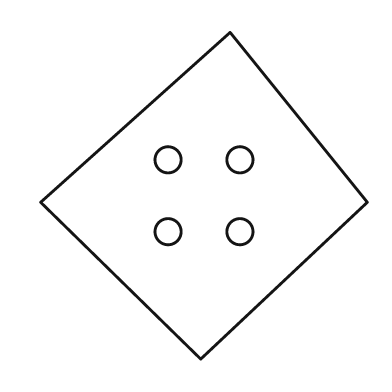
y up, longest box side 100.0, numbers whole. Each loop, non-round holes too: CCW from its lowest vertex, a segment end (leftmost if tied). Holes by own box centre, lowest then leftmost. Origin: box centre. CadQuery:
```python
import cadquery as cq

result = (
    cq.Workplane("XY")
    .moveTo(-1.0, -50.0)
    .lineTo(50.0, -2.0)
    .lineTo(8.0, 50.0)
    .lineTo(-50.0, -2.0)
    .close()
    .moveTo(-11.0, -11.0)
    .circle(4.0)
    .moveTo(11.0, -11.0)
    .circle(4.0)
    .moveTo(-11.0, 11.0)
    .circle(4.0)
    .moveTo(11.0, 11.0)
    .circle(4.0)
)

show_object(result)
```